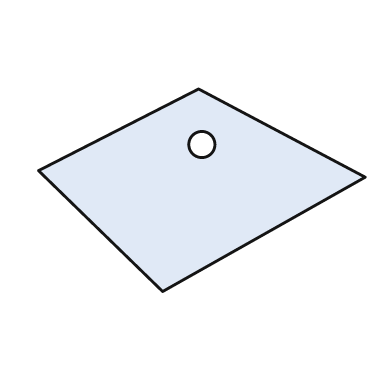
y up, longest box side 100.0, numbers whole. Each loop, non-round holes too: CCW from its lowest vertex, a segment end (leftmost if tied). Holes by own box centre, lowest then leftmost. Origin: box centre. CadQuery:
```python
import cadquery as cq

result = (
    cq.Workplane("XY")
    .moveTo(-12.0, -31.0)
    .lineTo(50.0, 4.0)
    .lineTo(-1.0, 31.0)
    .lineTo(-50.0, 6.0)
    .close()
    .moveTo(0.0, 14.0)
    .circle(4.0)
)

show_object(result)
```